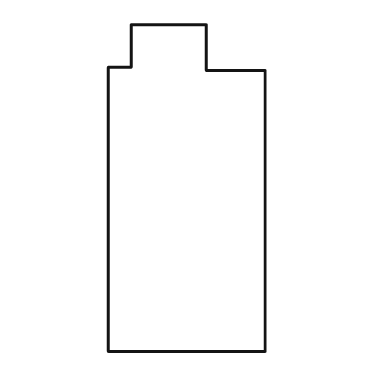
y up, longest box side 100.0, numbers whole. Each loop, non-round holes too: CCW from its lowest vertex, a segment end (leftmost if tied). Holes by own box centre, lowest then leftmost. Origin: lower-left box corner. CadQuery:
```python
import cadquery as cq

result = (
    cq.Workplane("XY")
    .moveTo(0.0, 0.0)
    .lineTo(48.0, 0.0)
    .lineTo(48.0, 86.0)
    .lineTo(30.0, 86.0)
    .lineTo(30.0, 100.0)
    .lineTo(7.0, 100.0)
    .lineTo(7.0, 87.0)
    .lineTo(0.0, 87.0)
    .close()
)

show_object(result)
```